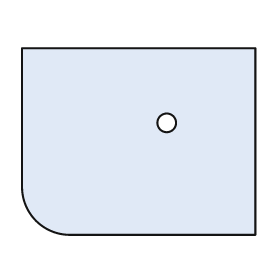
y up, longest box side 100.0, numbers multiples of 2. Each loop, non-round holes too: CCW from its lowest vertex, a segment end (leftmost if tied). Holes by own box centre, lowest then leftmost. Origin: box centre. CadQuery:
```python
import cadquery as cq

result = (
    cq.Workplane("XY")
    .moveTo(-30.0, -40.0)
    .lineTo(50.0, -40.0)
    .lineTo(50.0, 40.0)
    .lineTo(-50.0, 40.0)
    .lineTo(-50.0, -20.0)
    .threePointArc((-44.0, -34.0), (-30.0, -40.0))
    .close()
    .moveTo(12.0, 8.0)
    .circle(4.0)
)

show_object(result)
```